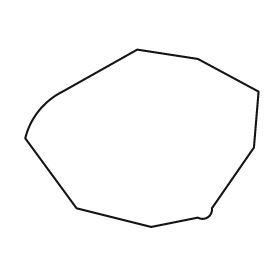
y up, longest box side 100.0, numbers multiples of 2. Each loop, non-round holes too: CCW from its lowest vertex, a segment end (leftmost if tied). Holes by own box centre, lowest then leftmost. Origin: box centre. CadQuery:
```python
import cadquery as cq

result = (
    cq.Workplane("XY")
    .moveTo(4.0, -38.0)
    .lineTo(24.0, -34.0)
    .threePointArc((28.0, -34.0), (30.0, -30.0))
    .lineTo(48.0, -4.0)
    .lineTo(50.0, 20.0)
    .lineTo(24.0, 34.0)
    .lineTo(-2.0, 38.0)
    .lineTo(-34.0, 20.0)
    .threePointArc((-44.0, 12.0), (-50.0, 0.0))
    .lineTo(-28.0, -30.0)
    .close()
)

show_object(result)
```